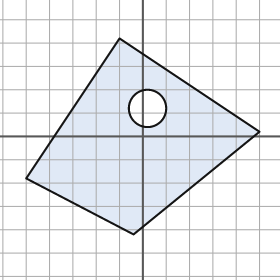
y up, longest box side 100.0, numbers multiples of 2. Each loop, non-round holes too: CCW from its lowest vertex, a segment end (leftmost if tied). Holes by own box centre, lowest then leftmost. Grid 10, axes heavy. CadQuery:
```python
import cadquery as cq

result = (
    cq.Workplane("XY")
    .moveTo(-4.0, -42.0)
    .lineTo(50.0, 2.0)
    .lineTo(-10.0, 42.0)
    .lineTo(-50.0, -18.0)
    .close()
    .moveTo(2.0, 12.0)
    .circle(8.0)
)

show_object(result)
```